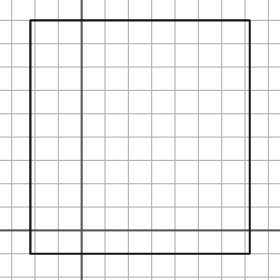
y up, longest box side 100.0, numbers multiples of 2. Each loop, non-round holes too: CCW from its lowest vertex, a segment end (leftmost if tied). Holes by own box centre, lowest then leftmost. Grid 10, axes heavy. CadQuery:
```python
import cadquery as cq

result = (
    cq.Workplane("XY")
    .moveTo(-22.0, -10.0)
    .lineTo(72.0, -10.0)
    .lineTo(72.0, 90.0)
    .lineTo(-22.0, 90.0)
    .close()
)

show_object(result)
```